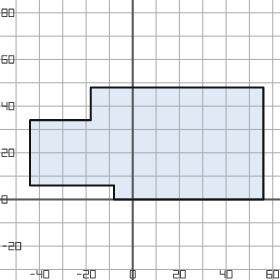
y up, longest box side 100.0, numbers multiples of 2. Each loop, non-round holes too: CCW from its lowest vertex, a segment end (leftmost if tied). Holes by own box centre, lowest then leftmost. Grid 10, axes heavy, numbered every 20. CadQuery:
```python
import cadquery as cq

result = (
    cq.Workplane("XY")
    .moveTo(-8.0, 0.0)
    .lineTo(56.0, 0.0)
    .lineTo(56.0, 48.0)
    .lineTo(-18.0, 48.0)
    .lineTo(-18.0, 34.0)
    .lineTo(-44.0, 34.0)
    .lineTo(-44.0, 6.0)
    .lineTo(-8.0, 6.0)
    .close()
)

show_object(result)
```